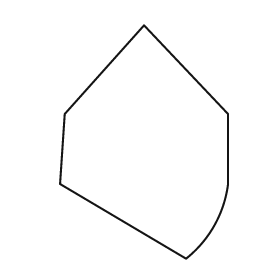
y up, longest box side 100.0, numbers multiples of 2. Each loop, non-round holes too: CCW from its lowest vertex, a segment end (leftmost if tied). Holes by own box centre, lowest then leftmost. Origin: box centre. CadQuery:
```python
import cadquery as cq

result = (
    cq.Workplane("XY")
    .moveTo(18.0, -50.0)
    .threePointArc((30.0, -36.0), (36.0, -18.0))
    .lineTo(36.0, 12.0)
    .lineTo(0.0, 50.0)
    .lineTo(-34.0, 12.0)
    .lineTo(-36.0, -18.0)
    .close()
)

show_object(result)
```